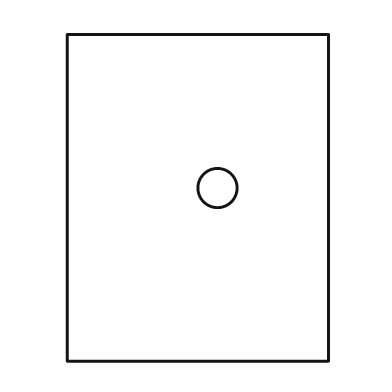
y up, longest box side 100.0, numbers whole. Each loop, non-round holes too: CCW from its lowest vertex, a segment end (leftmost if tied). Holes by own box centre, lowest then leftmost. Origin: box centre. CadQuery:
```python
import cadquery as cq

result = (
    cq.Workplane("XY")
    .moveTo(-40.0, -50.0)
    .lineTo(40.0, -50.0)
    .lineTo(40.0, 50.0)
    .lineTo(-40.0, 50.0)
    .close()
    .moveTo(6.0, 3.0)
    .circle(6.0)
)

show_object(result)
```